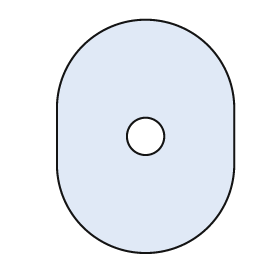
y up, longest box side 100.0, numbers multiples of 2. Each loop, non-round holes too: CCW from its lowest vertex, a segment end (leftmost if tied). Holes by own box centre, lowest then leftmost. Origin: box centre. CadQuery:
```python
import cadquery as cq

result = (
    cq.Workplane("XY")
    .moveTo(-38.0, -12.0)
    .threePointArc((0.0, -50.0), (38.0, -12.0))
    .lineTo(38.0, 12.0)
    .threePointArc((0.0, 50.0), (-38.0, 12.0))
    .close()
    .moveTo(0.0, 0.0)
    .circle(8.0)
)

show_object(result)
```